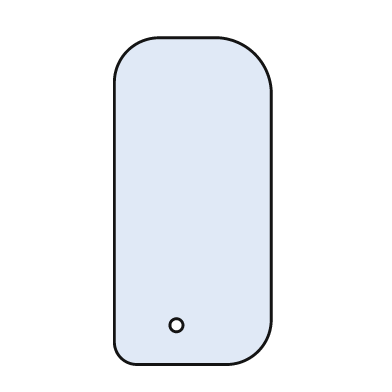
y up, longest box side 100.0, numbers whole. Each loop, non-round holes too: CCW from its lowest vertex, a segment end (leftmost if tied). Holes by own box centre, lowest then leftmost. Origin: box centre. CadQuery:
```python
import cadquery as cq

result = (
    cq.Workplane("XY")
    .moveTo(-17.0, -50.0)
    .lineTo(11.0, -50.0)
    .threePointArc((20.0, -46.0), (24.0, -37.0))
    .lineTo(24.0, 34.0)
    .threePointArc((19.0, 45.0), (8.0, 50.0))
    .lineTo(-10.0, 50.0)
    .threePointArc((-20.0, 46.0), (-24.0, 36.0))
    .lineTo(-24.0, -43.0)
    .threePointArc((-22.0, -48.0), (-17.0, -50.0))
    .close()
    .moveTo(-5.0, -38.0)
    .circle(2.0)
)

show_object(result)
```